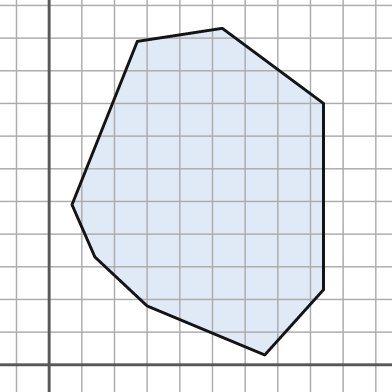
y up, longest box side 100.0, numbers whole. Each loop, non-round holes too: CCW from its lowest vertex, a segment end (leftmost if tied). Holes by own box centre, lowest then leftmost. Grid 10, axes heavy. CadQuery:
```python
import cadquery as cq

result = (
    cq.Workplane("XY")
    .moveTo(66.0, 3.0)
    .lineTo(84.0, 23.0)
    .lineTo(84.0, 80.0)
    .lineTo(53.0, 103.0)
    .lineTo(27.0, 99.0)
    .lineTo(7.0, 49.0)
    .lineTo(14.0, 33.0)
    .lineTo(30.0, 18.0)
    .close()
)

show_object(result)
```